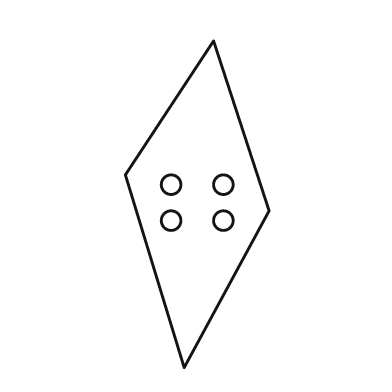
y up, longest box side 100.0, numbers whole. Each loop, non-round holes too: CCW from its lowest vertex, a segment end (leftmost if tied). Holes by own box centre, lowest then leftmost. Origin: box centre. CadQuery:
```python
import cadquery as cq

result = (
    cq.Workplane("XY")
    .moveTo(-4.0, -50.0)
    .lineTo(22.0, -2.0)
    .lineTo(5.0, 50.0)
    .lineTo(-22.0, 9.0)
    .close()
    .moveTo(-8.0, -5.0)
    .circle(3.0)
    .moveTo(8.0, -5.0)
    .circle(3.0)
    .moveTo(-8.0, 6.0)
    .circle(3.0)
    .moveTo(8.0, 6.0)
    .circle(3.0)
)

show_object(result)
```